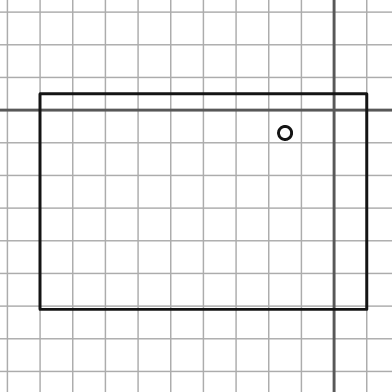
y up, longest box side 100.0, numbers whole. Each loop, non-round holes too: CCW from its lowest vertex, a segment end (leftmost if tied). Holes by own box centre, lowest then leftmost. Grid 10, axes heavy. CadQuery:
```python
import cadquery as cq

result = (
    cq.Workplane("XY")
    .moveTo(-90.0, -61.0)
    .lineTo(10.0, -61.0)
    .lineTo(10.0, 5.0)
    .lineTo(-90.0, 5.0)
    .close()
    .moveTo(-15.0, -7.0)
    .circle(2.0)
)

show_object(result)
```